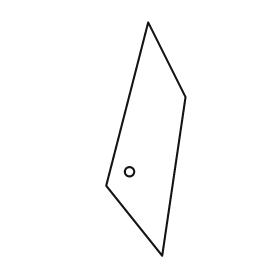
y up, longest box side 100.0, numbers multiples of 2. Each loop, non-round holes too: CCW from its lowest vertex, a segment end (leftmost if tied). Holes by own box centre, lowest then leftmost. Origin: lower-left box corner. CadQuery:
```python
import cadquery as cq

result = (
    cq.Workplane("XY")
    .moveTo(24.0, 0.0)
    .lineTo(34.0, 68.0)
    .lineTo(18.0, 100.0)
    .lineTo(0.0, 30.0)
    .close()
    .moveTo(10.0, 36.0)
    .circle(2.0)
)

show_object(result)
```